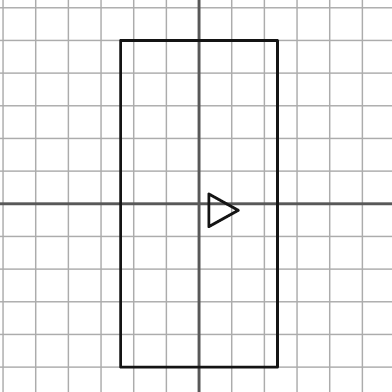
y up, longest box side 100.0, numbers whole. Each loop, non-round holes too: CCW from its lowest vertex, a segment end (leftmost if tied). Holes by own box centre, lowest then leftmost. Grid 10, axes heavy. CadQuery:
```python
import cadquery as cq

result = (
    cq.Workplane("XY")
    .moveTo(-24.0, -50.0)
    .lineTo(24.0, -50.0)
    .lineTo(24.0, 50.0)
    .lineTo(-24.0, 50.0)
    .close()
    .moveTo(3.0, -7.0)
    .lineTo(12.0, -2.0)
    .lineTo(3.0, 3.0)
    .close()
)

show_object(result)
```